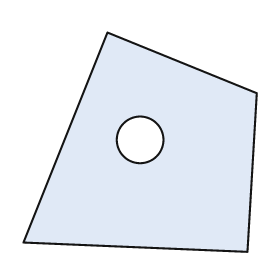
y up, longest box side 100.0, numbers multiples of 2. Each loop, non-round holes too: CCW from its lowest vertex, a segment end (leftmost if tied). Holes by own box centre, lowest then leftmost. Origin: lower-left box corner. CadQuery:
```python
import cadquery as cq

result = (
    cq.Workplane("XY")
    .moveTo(96.0, 0.0)
    .lineTo(100.0, 68.0)
    .lineTo(36.0, 94.0)
    .lineTo(0.0, 4.0)
    .close()
    .moveTo(50.0, 48.0)
    .circle(10.0)
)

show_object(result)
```